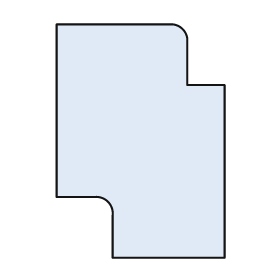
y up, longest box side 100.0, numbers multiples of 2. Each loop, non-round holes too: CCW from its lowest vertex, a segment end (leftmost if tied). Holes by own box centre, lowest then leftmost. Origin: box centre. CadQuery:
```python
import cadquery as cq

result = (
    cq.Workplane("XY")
    .moveTo(-12.0, -50.0)
    .lineTo(36.0, -50.0)
    .lineTo(36.0, 24.0)
    .lineTo(20.0, 24.0)
    .lineTo(20.0, 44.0)
    .threePointArc((18.0, 48.0), (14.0, 50.0))
    .lineTo(-36.0, 50.0)
    .lineTo(-36.0, -24.0)
    .lineTo(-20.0, -24.0)
    .threePointArc((-14.0, -26.0), (-12.0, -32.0))
    .close()
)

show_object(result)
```